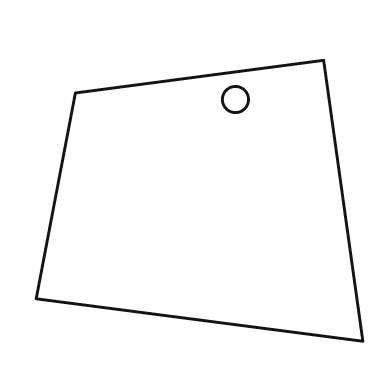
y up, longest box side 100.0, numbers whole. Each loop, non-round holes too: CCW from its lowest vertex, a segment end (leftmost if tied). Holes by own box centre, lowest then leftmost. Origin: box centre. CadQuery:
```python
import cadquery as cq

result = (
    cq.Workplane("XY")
    .moveTo(50.0, -43.0)
    .lineTo(38.0, 43.0)
    .lineTo(-38.0, 33.0)
    .lineTo(-50.0, -30.0)
    .close()
    .moveTo(11.0, 31.0)
    .circle(4.0)
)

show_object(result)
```